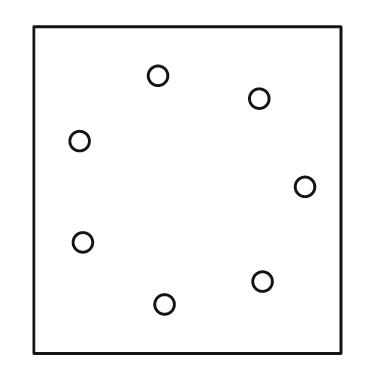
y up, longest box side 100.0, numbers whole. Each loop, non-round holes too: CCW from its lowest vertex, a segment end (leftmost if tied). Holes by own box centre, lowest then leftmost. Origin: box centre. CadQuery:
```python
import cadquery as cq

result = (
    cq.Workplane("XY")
    .moveTo(-47.0, -50.0)
    .lineTo(47.0, -50.0)
    .lineTo(47.0, 50.0)
    .lineTo(-47.0, 50.0)
    .close()
    .moveTo(-7.0, -35.0)
    .circle(3.0)
    .moveTo(23.0, -28.0)
    .circle(3.0)
    .moveTo(-32.0, -16.0)
    .circle(3.0)
    .moveTo(36.0, 1.0)
    .circle(3.0)
    .moveTo(-33.0, 15.0)
    .circle(3.0)
    .moveTo(22.0, 28.0)
    .circle(3.0)
    .moveTo(-9.0, 35.0)
    .circle(3.0)
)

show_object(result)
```